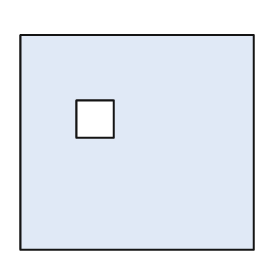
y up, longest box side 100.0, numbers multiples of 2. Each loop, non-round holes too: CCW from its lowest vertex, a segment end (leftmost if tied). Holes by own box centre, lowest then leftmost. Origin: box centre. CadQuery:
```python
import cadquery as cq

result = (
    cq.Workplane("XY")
    .moveTo(-50.0, -46.0)
    .lineTo(50.0, -46.0)
    .lineTo(50.0, 46.0)
    .lineTo(-50.0, 46.0)
    .close()
    .moveTo(-26.0, 2.0)
    .lineTo(-10.0, 2.0)
    .lineTo(-10.0, 18.0)
    .lineTo(-26.0, 18.0)
    .close()
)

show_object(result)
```